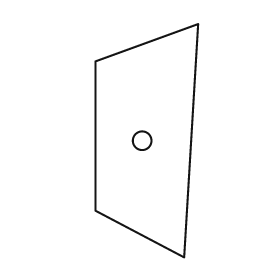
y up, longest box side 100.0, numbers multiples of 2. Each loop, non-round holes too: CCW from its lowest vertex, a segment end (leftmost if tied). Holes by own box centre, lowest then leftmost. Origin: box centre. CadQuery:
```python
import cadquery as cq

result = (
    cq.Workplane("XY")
    .moveTo(16.0, -50.0)
    .lineTo(22.0, 50.0)
    .lineTo(-22.0, 34.0)
    .lineTo(-22.0, -30.0)
    .close()
    .moveTo(-2.0, 0.0)
    .circle(4.0)
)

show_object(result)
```